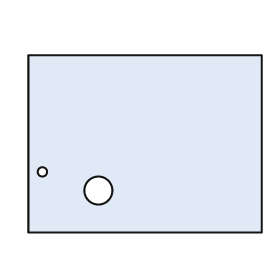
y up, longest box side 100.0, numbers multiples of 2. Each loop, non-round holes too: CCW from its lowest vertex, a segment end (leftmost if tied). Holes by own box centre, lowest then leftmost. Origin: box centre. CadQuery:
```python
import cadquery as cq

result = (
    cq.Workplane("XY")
    .moveTo(-50.0, -38.0)
    .lineTo(50.0, -38.0)
    .lineTo(50.0, 38.0)
    .lineTo(-50.0, 38.0)
    .close()
    .moveTo(-20.0, -20.0)
    .circle(6.0)
    .moveTo(-44.0, -12.0)
    .circle(2.0)
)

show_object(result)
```